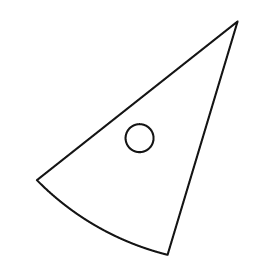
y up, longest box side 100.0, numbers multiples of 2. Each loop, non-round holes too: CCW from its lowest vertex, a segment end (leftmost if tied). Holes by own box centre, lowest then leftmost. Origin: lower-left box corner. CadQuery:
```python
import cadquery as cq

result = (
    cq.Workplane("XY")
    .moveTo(56.0, 0.0)
    .lineTo(86.0, 100.0)
    .lineTo(0.0, 32.0)
    .threePointArc((26.0, 12.0), (56.0, 0.0))
    .close()
    .moveTo(44.0, 50.0)
    .circle(6.0)
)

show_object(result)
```